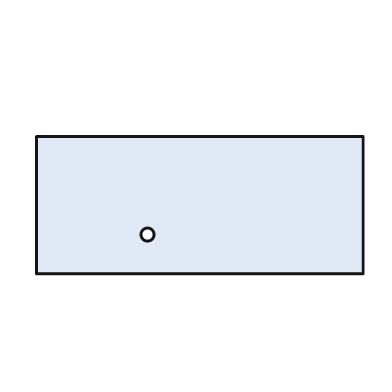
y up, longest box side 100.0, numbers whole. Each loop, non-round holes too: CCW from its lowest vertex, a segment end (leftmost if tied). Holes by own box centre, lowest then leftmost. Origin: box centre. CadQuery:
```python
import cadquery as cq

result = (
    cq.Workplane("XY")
    .moveTo(-50.0, -21.0)
    .lineTo(50.0, -21.0)
    .lineTo(50.0, 21.0)
    .lineTo(-50.0, 21.0)
    .close()
    .moveTo(-16.0, -9.0)
    .circle(2.0)
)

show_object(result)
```